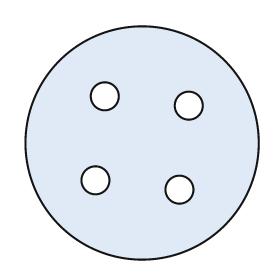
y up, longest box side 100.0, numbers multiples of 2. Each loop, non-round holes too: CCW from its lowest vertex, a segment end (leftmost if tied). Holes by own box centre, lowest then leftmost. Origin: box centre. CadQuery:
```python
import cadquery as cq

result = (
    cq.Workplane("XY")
    .moveTo(0.0, 0.0)
    .circle(50.0)
    .moveTo(16.0, -20.0)
    .circle(6.0)
    .moveTo(-20.0, -16.0)
    .circle(6.0)
    .moveTo(20.0, 16.0)
    .circle(6.0)
    .moveTo(-16.0, 20.0)
    .circle(6.0)
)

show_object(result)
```